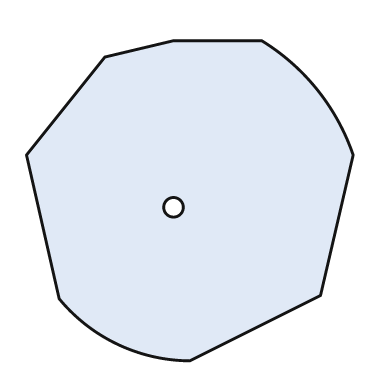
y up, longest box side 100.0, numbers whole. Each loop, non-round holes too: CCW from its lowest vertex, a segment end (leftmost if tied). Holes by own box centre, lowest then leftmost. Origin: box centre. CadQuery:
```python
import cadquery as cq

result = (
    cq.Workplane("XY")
    .moveTo(0.0, -49.0)
    .lineTo(40.0, -29.0)
    .lineTo(50.0, 14.0)
    .threePointArc((39.0, 34.0), (22.0, 49.0))
    .lineTo(-5.0, 49.0)
    .lineTo(-26.0, 44.0)
    .lineTo(-50.0, 14.0)
    .lineTo(-40.0, -30.0)
    .threePointArc((-22.0, -44.0), (0.0, -49.0))
    .close()
    .moveTo(-5.0, -2.0)
    .circle(3.0)
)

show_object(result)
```